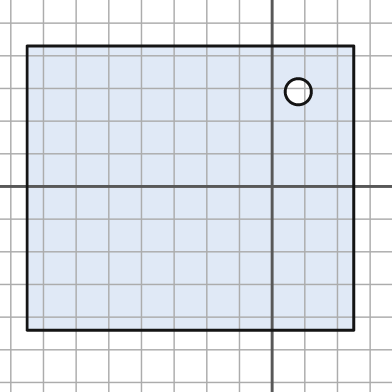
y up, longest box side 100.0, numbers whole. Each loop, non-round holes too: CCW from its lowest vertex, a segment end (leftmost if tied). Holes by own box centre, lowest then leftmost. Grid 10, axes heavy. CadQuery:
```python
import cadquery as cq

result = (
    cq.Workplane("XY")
    .moveTo(-75.0, -44.0)
    .lineTo(25.0, -44.0)
    .lineTo(25.0, 43.0)
    .lineTo(-75.0, 43.0)
    .close()
    .moveTo(8.0, 29.0)
    .circle(4.0)
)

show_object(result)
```